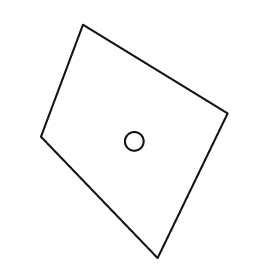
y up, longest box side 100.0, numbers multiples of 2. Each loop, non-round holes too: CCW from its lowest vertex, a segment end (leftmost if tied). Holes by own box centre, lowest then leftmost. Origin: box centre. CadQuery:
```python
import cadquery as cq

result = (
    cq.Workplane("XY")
    .moveTo(10.0, -50.0)
    .lineTo(40.0, 12.0)
    .lineTo(-22.0, 50.0)
    .lineTo(-40.0, 2.0)
    .close()
    .moveTo(0.0, 0.0)
    .circle(4.0)
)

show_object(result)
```